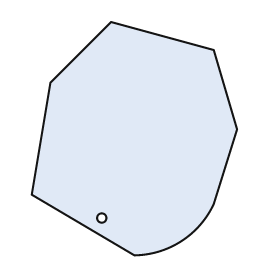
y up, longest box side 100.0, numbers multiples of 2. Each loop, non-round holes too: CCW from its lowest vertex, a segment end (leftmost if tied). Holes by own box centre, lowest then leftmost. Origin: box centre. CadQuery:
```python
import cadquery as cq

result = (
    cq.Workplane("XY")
    .moveTo(0.0, -50.0)
    .threePointArc((20.0, -44.0), (34.0, -28.0))
    .lineTo(44.0, 4.0)
    .lineTo(34.0, 38.0)
    .lineTo(-10.0, 50.0)
    .lineTo(-36.0, 24.0)
    .lineTo(-44.0, -24.0)
    .close()
    .moveTo(-14.0, -34.0)
    .circle(2.0)
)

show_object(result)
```